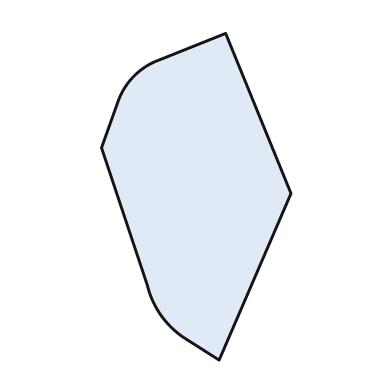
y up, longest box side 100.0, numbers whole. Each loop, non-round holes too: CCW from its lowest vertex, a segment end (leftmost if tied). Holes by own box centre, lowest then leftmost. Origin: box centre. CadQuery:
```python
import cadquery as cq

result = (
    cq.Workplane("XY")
    .moveTo(7.0, -50.0)
    .lineTo(29.0, 1.0)
    .lineTo(9.0, 50.0)
    .lineTo(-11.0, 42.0)
    .threePointArc((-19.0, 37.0), (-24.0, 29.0))
    .lineTo(-29.0, 15.0)
    .lineTo(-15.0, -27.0)
    .threePointArc((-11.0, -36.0), (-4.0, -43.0))
    .close()
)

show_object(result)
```